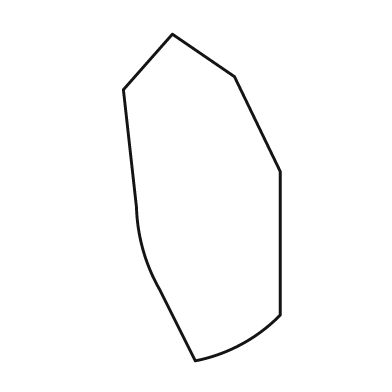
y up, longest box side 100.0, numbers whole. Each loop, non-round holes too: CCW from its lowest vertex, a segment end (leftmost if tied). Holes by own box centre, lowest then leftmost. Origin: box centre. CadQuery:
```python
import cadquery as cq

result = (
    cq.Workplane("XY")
    .moveTo(-2.0, -50.0)
    .threePointArc((12.0, -45.0), (24.0, -36.0))
    .lineTo(24.0, 8.0)
    .lineTo(10.0, 37.0)
    .lineTo(-9.0, 50.0)
    .lineTo(-24.0, 33.0)
    .lineTo(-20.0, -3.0)
    .threePointArc((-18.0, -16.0), (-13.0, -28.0))
    .close()
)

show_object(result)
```